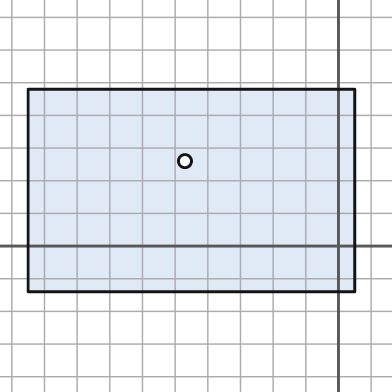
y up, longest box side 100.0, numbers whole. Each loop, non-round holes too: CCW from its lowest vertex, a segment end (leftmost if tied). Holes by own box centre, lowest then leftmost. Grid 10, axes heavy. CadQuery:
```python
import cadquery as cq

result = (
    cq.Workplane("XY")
    .moveTo(-95.0, -14.0)
    .lineTo(5.0, -14.0)
    .lineTo(5.0, 48.0)
    .lineTo(-95.0, 48.0)
    .close()
    .moveTo(-47.0, 26.0)
    .circle(2.0)
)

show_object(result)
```